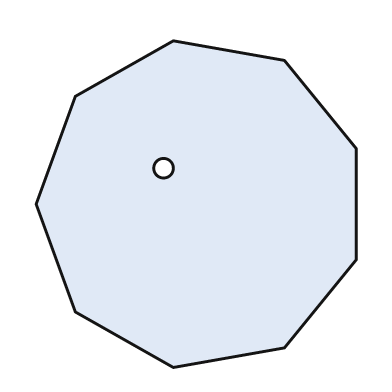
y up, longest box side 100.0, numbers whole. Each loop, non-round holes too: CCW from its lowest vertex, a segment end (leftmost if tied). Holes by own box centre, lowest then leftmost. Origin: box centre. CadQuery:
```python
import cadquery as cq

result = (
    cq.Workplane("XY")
    .moveTo(-7.0, -50.0)
    .lineTo(27.0, -44.0)
    .lineTo(49.0, -17.0)
    .lineTo(49.0, 17.0)
    .lineTo(27.0, 44.0)
    .lineTo(-7.0, 50.0)
    .lineTo(-37.0, 33.0)
    .lineTo(-49.0, 0.0)
    .lineTo(-37.0, -33.0)
    .close()
    .moveTo(-10.0, 11.0)
    .circle(3.0)
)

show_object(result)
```